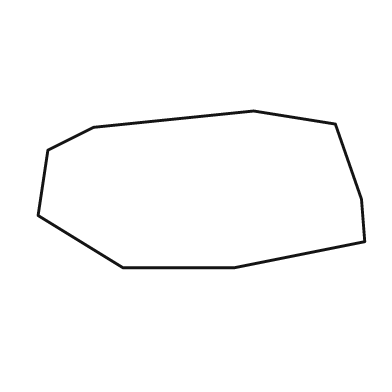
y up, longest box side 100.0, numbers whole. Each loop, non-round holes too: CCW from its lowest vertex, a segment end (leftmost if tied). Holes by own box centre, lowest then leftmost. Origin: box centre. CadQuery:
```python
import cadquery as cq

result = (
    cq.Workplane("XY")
    .moveTo(-24.0, -24.0)
    .lineTo(10.0, -24.0)
    .lineTo(50.0, -16.0)
    .lineTo(49.0, -3.0)
    .lineTo(41.0, 20.0)
    .lineTo(16.0, 24.0)
    .lineTo(-33.0, 19.0)
    .lineTo(-47.0, 12.0)
    .lineTo(-50.0, -8.0)
    .close()
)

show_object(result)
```